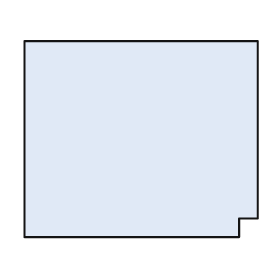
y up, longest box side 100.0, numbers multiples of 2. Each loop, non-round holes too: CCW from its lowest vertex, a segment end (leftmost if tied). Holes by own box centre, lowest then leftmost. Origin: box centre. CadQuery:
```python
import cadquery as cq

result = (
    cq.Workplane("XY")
    .moveTo(-50.0, -42.0)
    .lineTo(42.0, -42.0)
    .lineTo(42.0, -34.0)
    .lineTo(50.0, -34.0)
    .lineTo(50.0, 42.0)
    .lineTo(-50.0, 42.0)
    .close()
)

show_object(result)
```